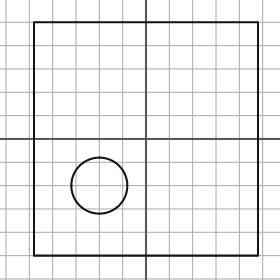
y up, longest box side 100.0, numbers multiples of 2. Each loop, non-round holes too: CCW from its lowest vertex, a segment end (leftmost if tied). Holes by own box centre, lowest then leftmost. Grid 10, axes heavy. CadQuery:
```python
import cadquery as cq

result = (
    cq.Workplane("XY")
    .moveTo(-48.0, -50.0)
    .lineTo(48.0, -50.0)
    .lineTo(48.0, 50.0)
    .lineTo(-48.0, 50.0)
    .close()
    .moveTo(-20.0, -20.0)
    .circle(12.0)
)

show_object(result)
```